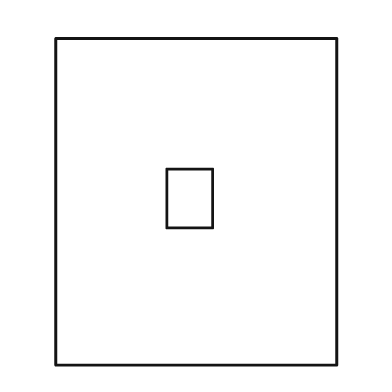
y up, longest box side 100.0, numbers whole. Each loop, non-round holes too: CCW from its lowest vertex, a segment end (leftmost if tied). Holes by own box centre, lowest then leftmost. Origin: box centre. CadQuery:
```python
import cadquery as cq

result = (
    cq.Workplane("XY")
    .moveTo(-43.0, -50.0)
    .lineTo(43.0, -50.0)
    .lineTo(43.0, 50.0)
    .lineTo(-43.0, 50.0)
    .close()
    .moveTo(-9.0, -8.0)
    .lineTo(5.0, -8.0)
    .lineTo(5.0, 10.0)
    .lineTo(-9.0, 10.0)
    .close()
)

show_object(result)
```